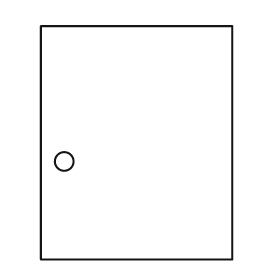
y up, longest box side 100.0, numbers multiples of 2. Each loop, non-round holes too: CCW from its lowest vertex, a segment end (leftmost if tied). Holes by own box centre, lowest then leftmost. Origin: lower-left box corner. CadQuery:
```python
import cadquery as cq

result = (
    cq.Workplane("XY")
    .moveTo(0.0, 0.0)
    .lineTo(82.0, 0.0)
    .lineTo(82.0, 100.0)
    .lineTo(0.0, 100.0)
    .close()
    .moveTo(10.0, 42.0)
    .circle(4.0)
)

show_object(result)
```